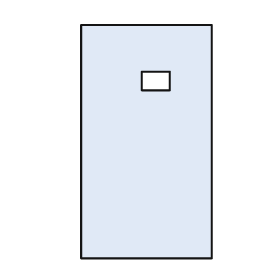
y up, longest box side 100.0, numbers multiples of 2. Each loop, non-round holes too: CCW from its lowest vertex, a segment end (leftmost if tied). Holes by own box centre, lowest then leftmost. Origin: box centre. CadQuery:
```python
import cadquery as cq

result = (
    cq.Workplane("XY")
    .moveTo(-28.0, -50.0)
    .lineTo(28.0, -50.0)
    .lineTo(28.0, 50.0)
    .lineTo(-28.0, 50.0)
    .close()
    .moveTo(-2.0, 22.0)
    .lineTo(10.0, 22.0)
    .lineTo(10.0, 30.0)
    .lineTo(-2.0, 30.0)
    .close()
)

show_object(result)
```